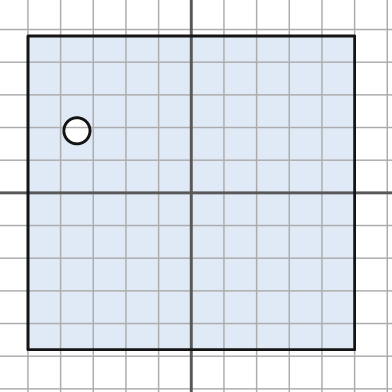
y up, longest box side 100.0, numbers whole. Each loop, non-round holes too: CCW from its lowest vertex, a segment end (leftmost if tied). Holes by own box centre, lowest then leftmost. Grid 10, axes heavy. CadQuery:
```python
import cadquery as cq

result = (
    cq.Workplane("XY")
    .moveTo(-50.0, -48.0)
    .lineTo(50.0, -48.0)
    .lineTo(50.0, 48.0)
    .lineTo(-50.0, 48.0)
    .close()
    .moveTo(-35.0, 19.0)
    .circle(4.0)
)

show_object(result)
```